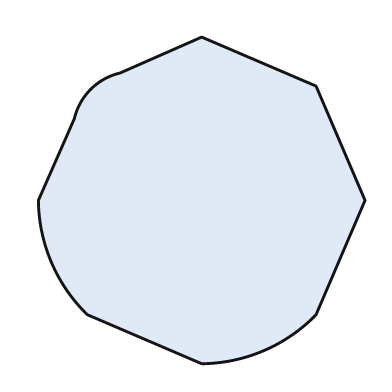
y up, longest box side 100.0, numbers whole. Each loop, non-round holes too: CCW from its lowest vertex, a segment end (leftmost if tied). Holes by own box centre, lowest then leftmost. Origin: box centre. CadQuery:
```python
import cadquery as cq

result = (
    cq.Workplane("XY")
    .moveTo(0.0, -50.0)
    .threePointArc((19.0, -46.0), (35.0, -35.0))
    .lineTo(50.0, 0.0)
    .lineTo(35.0, 35.0)
    .lineTo(0.0, 50.0)
    .lineTo(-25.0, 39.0)
    .threePointArc((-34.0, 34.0), (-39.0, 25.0))
    .lineTo(-50.0, 0.0)
    .threePointArc((-46.0, -19.0), (-35.0, -35.0))
    .close()
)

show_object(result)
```